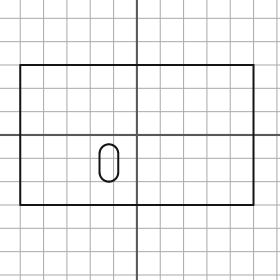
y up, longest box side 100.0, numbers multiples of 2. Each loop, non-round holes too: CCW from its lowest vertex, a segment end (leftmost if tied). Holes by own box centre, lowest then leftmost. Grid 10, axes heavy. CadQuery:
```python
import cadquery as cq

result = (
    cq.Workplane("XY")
    .moveTo(-50.0, -30.0)
    .lineTo(50.0, -30.0)
    .lineTo(50.0, 30.0)
    .lineTo(-50.0, 30.0)
    .close()
    .moveTo(-16.0, -16.0)
    .threePointArc((-12.0, -20.0), (-8.0, -16.0))
    .lineTo(-8.0, -8.0)
    .threePointArc((-12.0, -4.0), (-16.0, -8.0))
    .close()
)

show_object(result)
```